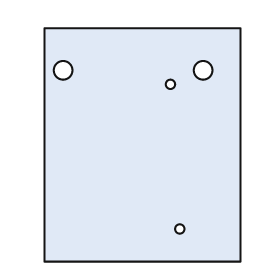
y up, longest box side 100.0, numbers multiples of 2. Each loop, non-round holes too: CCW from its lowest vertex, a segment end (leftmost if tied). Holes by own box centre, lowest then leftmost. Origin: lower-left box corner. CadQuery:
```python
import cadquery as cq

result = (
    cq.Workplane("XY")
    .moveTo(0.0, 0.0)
    .lineTo(84.0, 0.0)
    .lineTo(84.0, 100.0)
    .lineTo(0.0, 100.0)
    .close()
    .moveTo(58.0, 14.0)
    .circle(2.0)
    .moveTo(54.0, 76.0)
    .circle(2.0)
    .moveTo(8.0, 82.0)
    .circle(4.0)
    .moveTo(68.0, 82.0)
    .circle(4.0)
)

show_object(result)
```